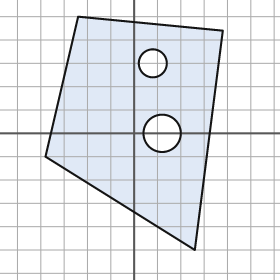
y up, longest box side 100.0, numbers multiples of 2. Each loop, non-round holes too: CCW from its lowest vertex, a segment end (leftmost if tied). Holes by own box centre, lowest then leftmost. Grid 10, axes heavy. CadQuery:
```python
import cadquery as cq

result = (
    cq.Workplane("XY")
    .moveTo(26.0, -50.0)
    .lineTo(38.0, 44.0)
    .lineTo(-24.0, 50.0)
    .lineTo(-38.0, -10.0)
    .close()
    .moveTo(12.0, 0.0)
    .circle(8.0)
    .moveTo(8.0, 30.0)
    .circle(6.0)
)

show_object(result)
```